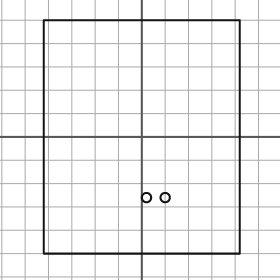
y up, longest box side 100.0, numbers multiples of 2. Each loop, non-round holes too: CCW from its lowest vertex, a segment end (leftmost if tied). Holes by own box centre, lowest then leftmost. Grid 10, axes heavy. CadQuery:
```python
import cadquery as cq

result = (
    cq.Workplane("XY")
    .moveTo(-42.0, -50.0)
    .lineTo(42.0, -50.0)
    .lineTo(42.0, 50.0)
    .lineTo(-42.0, 50.0)
    .close()
    .moveTo(2.0, -26.0)
    .circle(2.0)
    .moveTo(10.0, -26.0)
    .circle(2.0)
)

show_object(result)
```